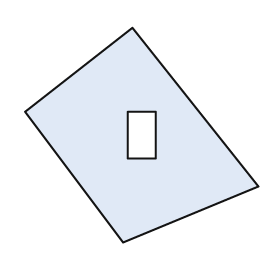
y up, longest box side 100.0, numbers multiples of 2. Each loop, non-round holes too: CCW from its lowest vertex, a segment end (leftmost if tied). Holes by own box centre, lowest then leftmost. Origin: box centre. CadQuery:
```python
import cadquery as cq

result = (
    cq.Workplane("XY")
    .moveTo(-8.0, -46.0)
    .lineTo(50.0, -22.0)
    .lineTo(-4.0, 46.0)
    .lineTo(-50.0, 10.0)
    .close()
    .moveTo(-6.0, -10.0)
    .lineTo(6.0, -10.0)
    .lineTo(6.0, 10.0)
    .lineTo(-6.0, 10.0)
    .close()
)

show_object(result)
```